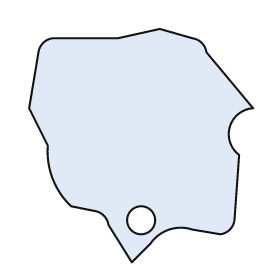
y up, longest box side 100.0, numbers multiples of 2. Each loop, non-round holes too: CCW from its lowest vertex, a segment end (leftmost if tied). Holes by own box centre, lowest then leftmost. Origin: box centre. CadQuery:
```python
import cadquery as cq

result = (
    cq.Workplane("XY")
    .moveTo(-4.0, -50.0)
    .lineTo(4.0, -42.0)
    .threePointArc((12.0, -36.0), (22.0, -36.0))
    .lineTo(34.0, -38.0)
    .threePointArc((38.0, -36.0), (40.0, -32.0))
    .lineTo(42.0, -4.0)
    .threePointArc((38.0, 8.0), (48.0, 16.0))
    .lineTo(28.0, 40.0)
    .threePointArc((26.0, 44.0), (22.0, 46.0))
    .lineTo(8.0, 50.0)
    .lineTo(-10.0, 46.0)
    .lineTo(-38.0, 46.0)
    .threePointArc((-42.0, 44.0), (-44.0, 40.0))
    .lineTo(-48.0, 16.0)
    .lineTo(-40.0, 0.0)
    .threePointArc((-38.0, -14.0), (-30.0, -26.0))
    .lineTo(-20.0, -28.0)
    .threePointArc((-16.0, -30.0), (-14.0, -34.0))
    .close()
    .moveTo(0.0, -32.0)
    .circle(6.0)
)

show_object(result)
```